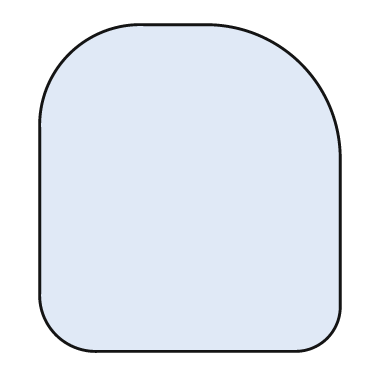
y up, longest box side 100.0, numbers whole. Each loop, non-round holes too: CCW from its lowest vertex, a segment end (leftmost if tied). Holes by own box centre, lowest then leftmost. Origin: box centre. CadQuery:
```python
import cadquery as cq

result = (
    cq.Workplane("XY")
    .moveTo(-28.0, -50.0)
    .lineTo(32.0, -50.0)
    .threePointArc((42.0, -46.0), (46.0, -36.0))
    .lineTo(46.0, 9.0)
    .threePointArc((34.0, 38.0), (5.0, 50.0))
    .lineTo(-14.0, 50.0)
    .threePointArc((-37.0, 41.0), (-46.0, 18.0))
    .lineTo(-46.0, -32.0)
    .threePointArc((-41.0, -45.0), (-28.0, -50.0))
    .close()
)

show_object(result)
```